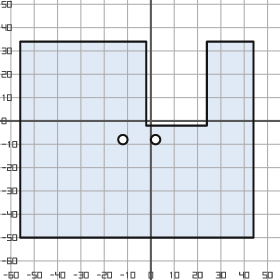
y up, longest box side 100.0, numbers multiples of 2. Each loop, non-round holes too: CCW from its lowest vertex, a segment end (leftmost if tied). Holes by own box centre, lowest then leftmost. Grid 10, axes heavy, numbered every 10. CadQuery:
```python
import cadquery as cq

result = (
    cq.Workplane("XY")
    .moveTo(-56.0, -50.0)
    .lineTo(44.0, -50.0)
    .lineTo(44.0, 34.0)
    .lineTo(24.0, 34.0)
    .lineTo(24.0, -2.0)
    .lineTo(-2.0, -2.0)
    .lineTo(-2.0, 34.0)
    .lineTo(-56.0, 34.0)
    .close()
    .moveTo(-12.0, -8.0)
    .circle(2.0)
    .moveTo(2.0, -8.0)
    .circle(2.0)
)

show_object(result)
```